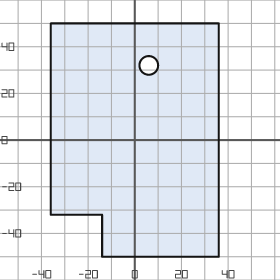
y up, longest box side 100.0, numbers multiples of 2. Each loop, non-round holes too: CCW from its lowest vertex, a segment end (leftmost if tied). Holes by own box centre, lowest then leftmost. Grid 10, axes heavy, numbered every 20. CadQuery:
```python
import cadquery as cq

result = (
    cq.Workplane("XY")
    .moveTo(-14.0, -50.0)
    .lineTo(36.0, -50.0)
    .lineTo(36.0, 50.0)
    .lineTo(-36.0, 50.0)
    .lineTo(-36.0, -32.0)
    .lineTo(-14.0, -32.0)
    .close()
    .moveTo(6.0, 32.0)
    .circle(4.0)
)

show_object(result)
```